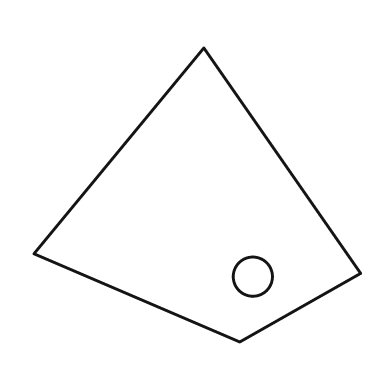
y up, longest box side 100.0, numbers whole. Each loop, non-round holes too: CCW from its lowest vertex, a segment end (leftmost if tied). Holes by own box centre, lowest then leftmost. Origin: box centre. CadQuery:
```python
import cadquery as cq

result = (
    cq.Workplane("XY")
    .moveTo(13.0, -45.0)
    .lineTo(50.0, -24.0)
    .lineTo(2.0, 45.0)
    .lineTo(-50.0, -18.0)
    .close()
    .moveTo(17.0, -25.0)
    .circle(6.0)
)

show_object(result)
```